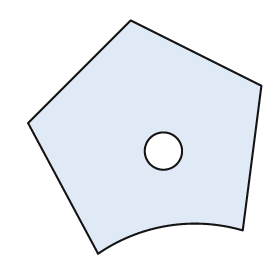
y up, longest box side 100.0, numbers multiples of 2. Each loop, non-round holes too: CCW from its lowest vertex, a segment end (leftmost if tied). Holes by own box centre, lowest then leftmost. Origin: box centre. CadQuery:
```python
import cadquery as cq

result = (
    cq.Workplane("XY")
    .moveTo(-20.0, -50.0)
    .threePointArc((10.0, -38.0), (42.0, -40.0))
    .lineTo(50.0, 22.0)
    .lineTo(-6.0, 50.0)
    .lineTo(-50.0, 6.0)
    .close()
    .moveTo(8.0, -6.0)
    .circle(8.0)
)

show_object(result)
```